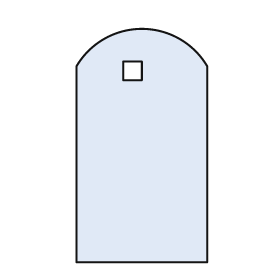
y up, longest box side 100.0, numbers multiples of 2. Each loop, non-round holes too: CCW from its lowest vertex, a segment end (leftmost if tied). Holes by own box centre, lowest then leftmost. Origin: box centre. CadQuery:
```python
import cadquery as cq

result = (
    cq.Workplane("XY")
    .moveTo(-28.0, -50.0)
    .lineTo(28.0, -50.0)
    .lineTo(28.0, 34.0)
    .threePointArc((0.0, 50.0), (-28.0, 34.0))
    .close()
    .moveTo(-8.0, 28.0)
    .lineTo(0.0, 28.0)
    .lineTo(0.0, 36.0)
    .lineTo(-8.0, 36.0)
    .close()
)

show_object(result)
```